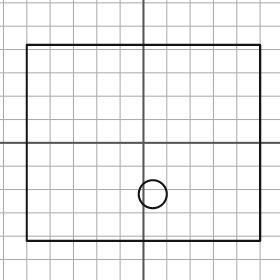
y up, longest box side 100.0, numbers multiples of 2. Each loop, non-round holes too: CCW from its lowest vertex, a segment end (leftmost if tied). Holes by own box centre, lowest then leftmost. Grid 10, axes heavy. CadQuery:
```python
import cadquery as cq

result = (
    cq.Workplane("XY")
    .moveTo(-50.0, -42.0)
    .lineTo(50.0, -42.0)
    .lineTo(50.0, 42.0)
    .lineTo(-50.0, 42.0)
    .close()
    .moveTo(4.0, -22.0)
    .circle(6.0)
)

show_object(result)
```